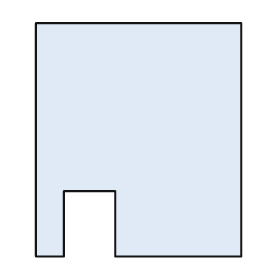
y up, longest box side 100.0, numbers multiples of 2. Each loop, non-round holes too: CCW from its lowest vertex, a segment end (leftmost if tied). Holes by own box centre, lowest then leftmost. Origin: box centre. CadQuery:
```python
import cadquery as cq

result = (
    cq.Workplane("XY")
    .moveTo(-44.0, -50.0)
    .lineTo(-32.0, -50.0)
    .lineTo(-32.0, -22.0)
    .lineTo(-10.0, -22.0)
    .lineTo(-10.0, -50.0)
    .lineTo(44.0, -50.0)
    .lineTo(44.0, 50.0)
    .lineTo(-44.0, 50.0)
    .close()
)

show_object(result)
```